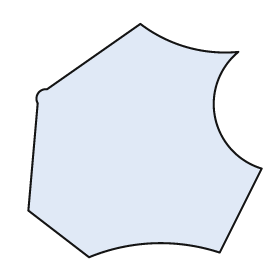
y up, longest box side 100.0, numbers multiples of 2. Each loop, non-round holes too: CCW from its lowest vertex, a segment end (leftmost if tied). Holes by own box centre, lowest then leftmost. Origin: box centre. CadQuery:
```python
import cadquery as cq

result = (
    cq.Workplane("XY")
    .moveTo(-24.0, -50.0)
    .threePointArc((4.0, -44.0), (32.0, -48.0))
    .lineTo(50.0, -12.0)
    .threePointArc((30.0, 10.0), (40.0, 38.0))
    .threePointArc((18.0, 40.0), (-2.0, 50.0))
    .lineTo(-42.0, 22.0)
    .threePointArc((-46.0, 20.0), (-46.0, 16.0))
    .lineTo(-50.0, -30.0)
    .close()
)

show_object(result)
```